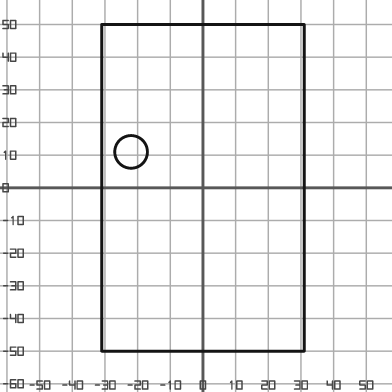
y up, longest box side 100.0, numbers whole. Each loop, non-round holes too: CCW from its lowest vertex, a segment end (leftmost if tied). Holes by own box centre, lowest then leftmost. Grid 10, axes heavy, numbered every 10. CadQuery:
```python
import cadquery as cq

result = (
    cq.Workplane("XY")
    .moveTo(-31.0, -50.0)
    .lineTo(31.0, -50.0)
    .lineTo(31.0, 50.0)
    .lineTo(-31.0, 50.0)
    .close()
    .moveTo(-22.0, 11.0)
    .circle(5.0)
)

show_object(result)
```